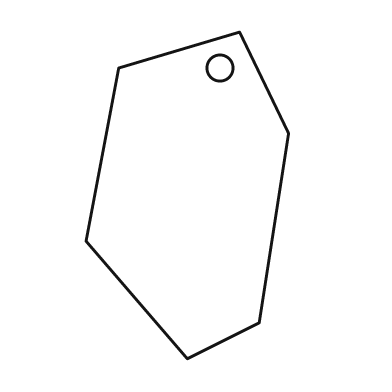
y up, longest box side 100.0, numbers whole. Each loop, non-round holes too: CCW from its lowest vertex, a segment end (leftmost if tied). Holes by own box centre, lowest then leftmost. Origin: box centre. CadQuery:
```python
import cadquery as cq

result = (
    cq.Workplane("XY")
    .moveTo(0.0, -50.0)
    .lineTo(22.0, -39.0)
    .lineTo(31.0, 19.0)
    .lineTo(16.0, 50.0)
    .lineTo(-21.0, 39.0)
    .lineTo(-31.0, -14.0)
    .close()
    .moveTo(10.0, 39.0)
    .circle(4.0)
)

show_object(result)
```